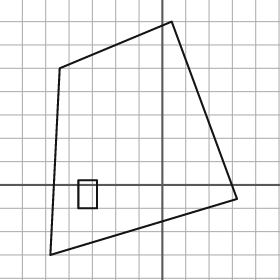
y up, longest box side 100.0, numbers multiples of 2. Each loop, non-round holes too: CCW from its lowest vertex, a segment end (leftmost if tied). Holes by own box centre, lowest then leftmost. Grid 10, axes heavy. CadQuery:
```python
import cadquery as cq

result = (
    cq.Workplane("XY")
    .moveTo(-48.0, -30.0)
    .lineTo(32.0, -6.0)
    .lineTo(4.0, 70.0)
    .lineTo(-44.0, 50.0)
    .close()
    .moveTo(-36.0, -10.0)
    .lineTo(-28.0, -10.0)
    .lineTo(-28.0, 2.0)
    .lineTo(-36.0, 2.0)
    .close()
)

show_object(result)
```